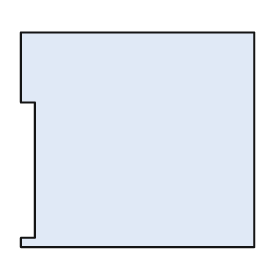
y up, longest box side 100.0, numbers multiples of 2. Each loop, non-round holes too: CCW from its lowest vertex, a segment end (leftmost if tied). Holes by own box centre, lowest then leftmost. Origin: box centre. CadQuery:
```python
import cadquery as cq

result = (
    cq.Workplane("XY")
    .moveTo(-50.0, -46.0)
    .lineTo(50.0, -46.0)
    .lineTo(50.0, 46.0)
    .lineTo(-50.0, 46.0)
    .lineTo(-50.0, 16.0)
    .lineTo(-44.0, 16.0)
    .lineTo(-44.0, -42.0)
    .lineTo(-50.0, -42.0)
    .close()
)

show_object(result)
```